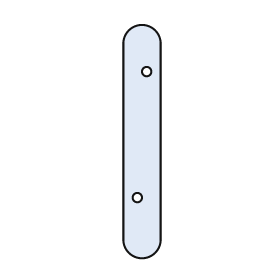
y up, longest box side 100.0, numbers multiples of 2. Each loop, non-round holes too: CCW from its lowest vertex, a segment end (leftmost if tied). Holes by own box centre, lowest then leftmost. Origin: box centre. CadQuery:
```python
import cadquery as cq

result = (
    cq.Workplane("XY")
    .moveTo(-8.0, -42.0)
    .threePointArc((0.0, -50.0), (8.0, -42.0))
    .lineTo(8.0, 42.0)
    .threePointArc((0.0, 50.0), (-8.0, 42.0))
    .close()
    .moveTo(-2.0, -24.0)
    .circle(2.0)
    .moveTo(2.0, 30.0)
    .circle(2.0)
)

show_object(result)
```